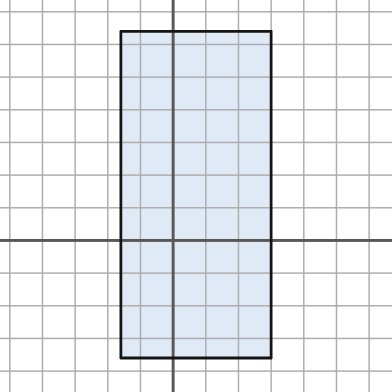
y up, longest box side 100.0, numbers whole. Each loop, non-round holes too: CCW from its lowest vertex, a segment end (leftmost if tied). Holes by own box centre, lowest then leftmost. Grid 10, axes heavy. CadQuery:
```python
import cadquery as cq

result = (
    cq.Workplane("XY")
    .moveTo(-16.0, -36.0)
    .lineTo(30.0, -36.0)
    .lineTo(30.0, 64.0)
    .lineTo(-16.0, 64.0)
    .close()
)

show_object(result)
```